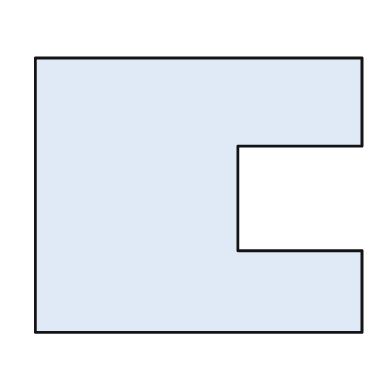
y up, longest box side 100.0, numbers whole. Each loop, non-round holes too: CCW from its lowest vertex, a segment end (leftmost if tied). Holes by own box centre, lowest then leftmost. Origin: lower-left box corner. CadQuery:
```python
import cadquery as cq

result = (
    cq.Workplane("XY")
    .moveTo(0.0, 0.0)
    .lineTo(100.0, 0.0)
    .lineTo(100.0, 25.0)
    .lineTo(62.0, 25.0)
    .lineTo(62.0, 57.0)
    .lineTo(100.0, 57.0)
    .lineTo(100.0, 84.0)
    .lineTo(0.0, 84.0)
    .close()
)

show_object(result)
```